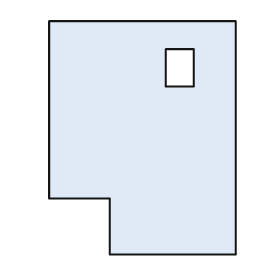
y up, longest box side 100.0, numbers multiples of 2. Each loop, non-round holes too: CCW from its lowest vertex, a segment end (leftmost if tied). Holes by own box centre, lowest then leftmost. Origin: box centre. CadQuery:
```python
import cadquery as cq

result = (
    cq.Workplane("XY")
    .moveTo(-14.0, -50.0)
    .lineTo(40.0, -50.0)
    .lineTo(40.0, 50.0)
    .lineTo(-40.0, 50.0)
    .lineTo(-40.0, -26.0)
    .lineTo(-14.0, -26.0)
    .close()
    .moveTo(10.0, 22.0)
    .lineTo(22.0, 22.0)
    .lineTo(22.0, 38.0)
    .lineTo(10.0, 38.0)
    .close()
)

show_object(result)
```